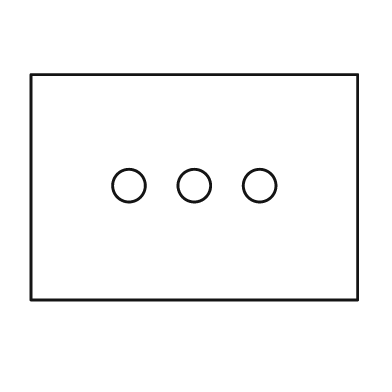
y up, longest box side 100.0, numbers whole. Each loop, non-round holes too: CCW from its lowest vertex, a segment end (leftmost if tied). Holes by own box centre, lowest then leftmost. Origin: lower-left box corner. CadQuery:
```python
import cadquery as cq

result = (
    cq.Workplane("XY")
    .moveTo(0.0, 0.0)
    .lineTo(100.0, 0.0)
    .lineTo(100.0, 69.0)
    .lineTo(0.0, 69.0)
    .close()
    .moveTo(30.0, 35.0)
    .circle(5.0)
    .moveTo(50.0, 35.0)
    .circle(5.0)
    .moveTo(70.0, 35.0)
    .circle(5.0)
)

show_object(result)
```